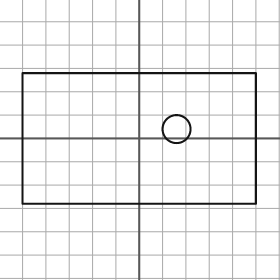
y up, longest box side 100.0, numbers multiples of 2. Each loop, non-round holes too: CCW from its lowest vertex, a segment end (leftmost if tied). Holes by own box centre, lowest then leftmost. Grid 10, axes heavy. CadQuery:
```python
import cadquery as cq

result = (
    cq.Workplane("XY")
    .moveTo(-50.0, -28.0)
    .lineTo(50.0, -28.0)
    .lineTo(50.0, 28.0)
    .lineTo(-50.0, 28.0)
    .close()
    .moveTo(16.0, 4.0)
    .circle(6.0)
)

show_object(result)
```